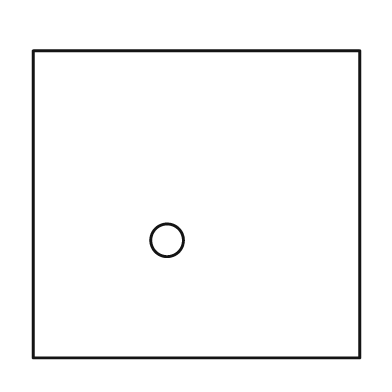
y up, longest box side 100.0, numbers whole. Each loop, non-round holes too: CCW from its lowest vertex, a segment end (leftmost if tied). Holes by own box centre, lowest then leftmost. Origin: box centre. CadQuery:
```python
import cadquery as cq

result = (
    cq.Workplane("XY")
    .moveTo(-50.0, -47.0)
    .lineTo(50.0, -47.0)
    .lineTo(50.0, 47.0)
    .lineTo(-50.0, 47.0)
    .close()
    .moveTo(-9.0, -11.0)
    .circle(5.0)
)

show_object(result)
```